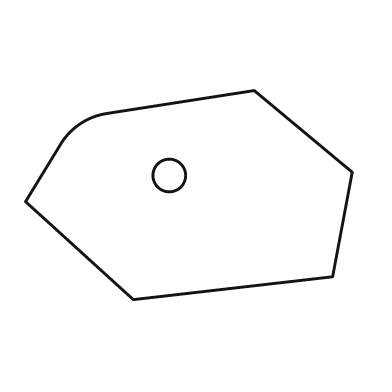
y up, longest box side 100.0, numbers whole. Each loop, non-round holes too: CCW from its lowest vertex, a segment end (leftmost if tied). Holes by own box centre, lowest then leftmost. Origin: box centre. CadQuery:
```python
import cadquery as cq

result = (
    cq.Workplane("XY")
    .moveTo(-17.0, -32.0)
    .lineTo(44.0, -25.0)
    .lineTo(50.0, 7.0)
    .lineTo(20.0, 32.0)
    .lineTo(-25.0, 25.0)
    .threePointArc((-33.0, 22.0), (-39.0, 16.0))
    .lineTo(-50.0, -2.0)
    .close()
    .moveTo(-6.0, 6.0)
    .circle(5.0)
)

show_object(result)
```